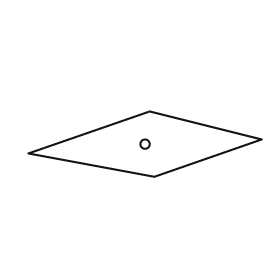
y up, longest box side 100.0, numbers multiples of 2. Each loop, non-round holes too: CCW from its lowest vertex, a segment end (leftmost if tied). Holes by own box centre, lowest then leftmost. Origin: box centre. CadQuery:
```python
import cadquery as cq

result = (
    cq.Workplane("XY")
    .moveTo(4.0, -14.0)
    .lineTo(50.0, 2.0)
    .lineTo(2.0, 14.0)
    .lineTo(-50.0, -4.0)
    .close()
    .moveTo(0.0, 0.0)
    .circle(2.0)
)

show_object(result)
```